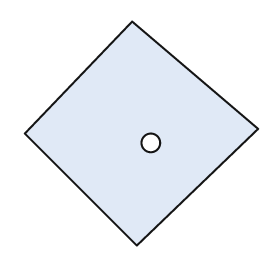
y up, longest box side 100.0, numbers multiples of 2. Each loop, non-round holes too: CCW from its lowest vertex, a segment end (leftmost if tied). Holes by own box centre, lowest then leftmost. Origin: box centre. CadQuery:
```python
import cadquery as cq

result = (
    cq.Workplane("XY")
    .moveTo(-2.0, -48.0)
    .lineTo(50.0, 2.0)
    .lineTo(-4.0, 48.0)
    .lineTo(-50.0, 0.0)
    .close()
    .moveTo(4.0, -4.0)
    .circle(4.0)
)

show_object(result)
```